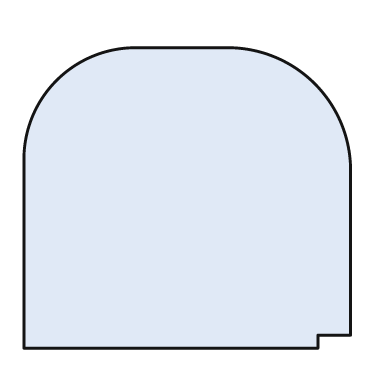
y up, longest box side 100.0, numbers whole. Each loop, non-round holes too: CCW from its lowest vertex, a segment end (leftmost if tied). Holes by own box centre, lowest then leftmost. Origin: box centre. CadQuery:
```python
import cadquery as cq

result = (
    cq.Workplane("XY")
    .moveTo(-50.0, -46.0)
    .lineTo(40.0, -46.0)
    .lineTo(40.0, -42.0)
    .lineTo(50.0, -42.0)
    .lineTo(50.0, 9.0)
    .threePointArc((39.0, 35.0), (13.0, 46.0))
    .lineTo(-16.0, 46.0)
    .threePointArc((-40.0, 36.0), (-50.0, 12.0))
    .close()
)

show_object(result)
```